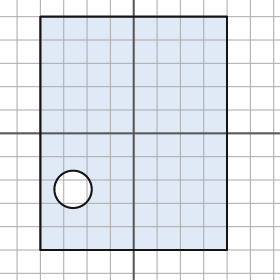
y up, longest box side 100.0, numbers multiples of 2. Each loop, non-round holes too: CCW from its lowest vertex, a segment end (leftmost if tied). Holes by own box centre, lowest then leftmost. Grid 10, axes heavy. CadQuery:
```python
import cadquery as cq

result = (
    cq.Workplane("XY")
    .moveTo(-40.0, -50.0)
    .lineTo(40.0, -50.0)
    .lineTo(40.0, 50.0)
    .lineTo(-40.0, 50.0)
    .close()
    .moveTo(-26.0, -24.0)
    .circle(8.0)
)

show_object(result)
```